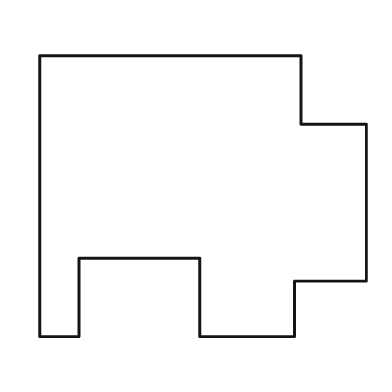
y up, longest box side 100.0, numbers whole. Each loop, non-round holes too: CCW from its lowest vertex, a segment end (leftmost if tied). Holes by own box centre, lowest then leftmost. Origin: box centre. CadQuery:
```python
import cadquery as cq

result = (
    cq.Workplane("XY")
    .moveTo(-50.0, -43.0)
    .lineTo(-38.0, -43.0)
    .lineTo(-38.0, -19.0)
    .lineTo(-1.0, -19.0)
    .lineTo(-1.0, -43.0)
    .lineTo(28.0, -43.0)
    .lineTo(28.0, -26.0)
    .lineTo(50.0, -26.0)
    .lineTo(50.0, 22.0)
    .lineTo(30.0, 22.0)
    .lineTo(30.0, 43.0)
    .lineTo(-50.0, 43.0)
    .close()
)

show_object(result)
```